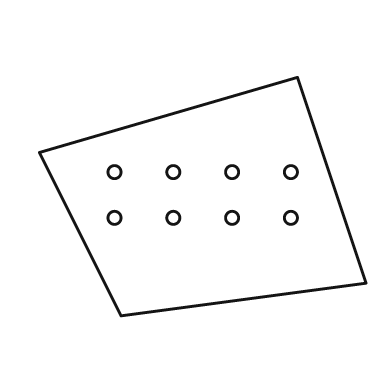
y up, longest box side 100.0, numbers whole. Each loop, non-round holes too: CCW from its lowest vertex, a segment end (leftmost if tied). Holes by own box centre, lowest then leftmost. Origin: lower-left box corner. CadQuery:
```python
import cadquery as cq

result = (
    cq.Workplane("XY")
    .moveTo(25.0, 0.0)
    .lineTo(100.0, 10.0)
    .lineTo(79.0, 73.0)
    .lineTo(0.0, 50.0)
    .close()
    .moveTo(23.0, 30.0)
    .circle(2.0)
    .moveTo(41.0, 30.0)
    .circle(2.0)
    .moveTo(59.0, 30.0)
    .circle(2.0)
    .moveTo(77.0, 30.0)
    .circle(2.0)
    .moveTo(23.0, 44.0)
    .circle(2.0)
    .moveTo(41.0, 44.0)
    .circle(2.0)
    .moveTo(59.0, 44.0)
    .circle(2.0)
    .moveTo(77.0, 44.0)
    .circle(2.0)
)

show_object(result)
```